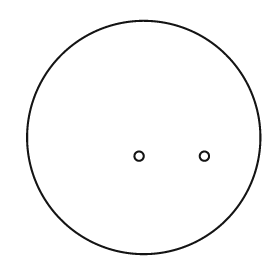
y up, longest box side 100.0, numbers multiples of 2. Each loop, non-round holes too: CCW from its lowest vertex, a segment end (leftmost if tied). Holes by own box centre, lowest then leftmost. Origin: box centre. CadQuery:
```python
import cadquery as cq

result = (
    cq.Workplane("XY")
    .moveTo(0.0, 0.0)
    .circle(50.0)
    .moveTo(-2.0, -8.0)
    .circle(2.0)
    .moveTo(26.0, -8.0)
    .circle(2.0)
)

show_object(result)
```